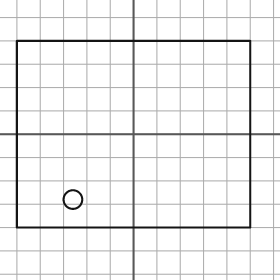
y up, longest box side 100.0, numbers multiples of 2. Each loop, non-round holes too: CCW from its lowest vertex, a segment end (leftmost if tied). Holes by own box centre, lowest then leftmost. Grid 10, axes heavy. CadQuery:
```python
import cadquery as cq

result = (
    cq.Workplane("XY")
    .moveTo(-50.0, -40.0)
    .lineTo(50.0, -40.0)
    .lineTo(50.0, 40.0)
    .lineTo(-50.0, 40.0)
    .close()
    .moveTo(-26.0, -28.0)
    .circle(4.0)
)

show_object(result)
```